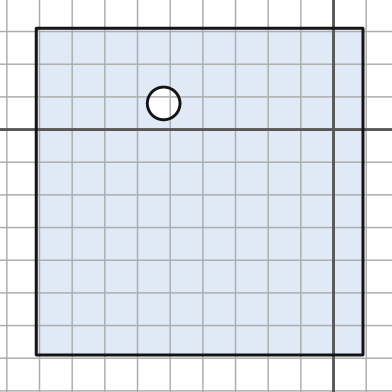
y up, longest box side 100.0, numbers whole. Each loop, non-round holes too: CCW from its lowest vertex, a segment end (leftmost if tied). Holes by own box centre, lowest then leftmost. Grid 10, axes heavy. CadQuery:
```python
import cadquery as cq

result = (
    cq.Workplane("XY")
    .moveTo(-91.0, -69.0)
    .lineTo(9.0, -69.0)
    .lineTo(9.0, 31.0)
    .lineTo(-91.0, 31.0)
    .close()
    .moveTo(-52.0, 8.0)
    .circle(5.0)
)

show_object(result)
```